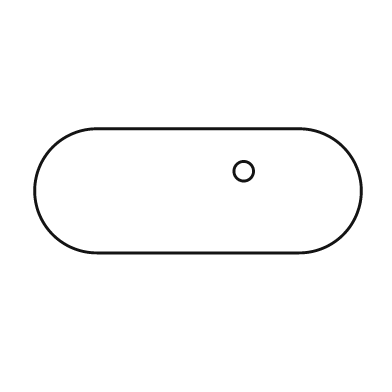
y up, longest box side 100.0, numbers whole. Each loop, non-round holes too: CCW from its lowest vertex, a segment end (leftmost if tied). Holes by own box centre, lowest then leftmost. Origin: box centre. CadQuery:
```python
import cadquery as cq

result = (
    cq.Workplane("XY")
    .moveTo(-31.0, -19.0)
    .lineTo(31.0, -19.0)
    .threePointArc((50.0, 0.0), (31.0, 19.0))
    .lineTo(-31.0, 19.0)
    .threePointArc((-50.0, 0.0), (-31.0, -19.0))
    .close()
    .moveTo(14.0, 6.0)
    .circle(3.0)
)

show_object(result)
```